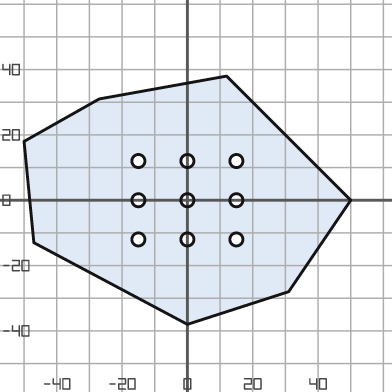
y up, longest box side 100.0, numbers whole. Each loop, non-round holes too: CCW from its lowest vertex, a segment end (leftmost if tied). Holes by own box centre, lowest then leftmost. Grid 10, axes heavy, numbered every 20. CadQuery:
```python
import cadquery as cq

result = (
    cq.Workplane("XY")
    .moveTo(0.0, -38.0)
    .lineTo(31.0, -28.0)
    .lineTo(50.0, 0.0)
    .lineTo(12.0, 38.0)
    .lineTo(-27.0, 31.0)
    .lineTo(-50.0, 18.0)
    .lineTo(-47.0, -13.0)
    .close()
    .moveTo(-15.0, -12.0)
    .circle(2.0)
    .moveTo(0.0, -12.0)
    .circle(2.0)
    .moveTo(15.0, -12.0)
    .circle(2.0)
    .moveTo(-15.0, 0.0)
    .circle(2.0)
    .moveTo(0.0, 0.0)
    .circle(2.0)
    .moveTo(15.0, 0.0)
    .circle(2.0)
    .moveTo(-15.0, 12.0)
    .circle(2.0)
    .moveTo(0.0, 12.0)
    .circle(2.0)
    .moveTo(15.0, 12.0)
    .circle(2.0)
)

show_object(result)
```